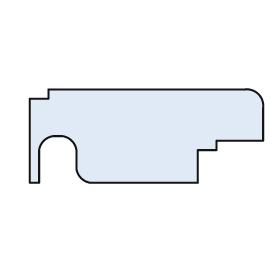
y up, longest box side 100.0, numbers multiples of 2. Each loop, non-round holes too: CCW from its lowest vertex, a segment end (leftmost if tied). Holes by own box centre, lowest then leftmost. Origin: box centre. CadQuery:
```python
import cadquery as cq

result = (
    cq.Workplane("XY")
    .moveTo(-50.0, -20.0)
    .lineTo(-46.0, -20.0)
    .lineTo(-46.0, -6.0)
    .threePointArc((-44.0, -2.0), (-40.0, 0.0))
    .lineTo(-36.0, 0.0)
    .threePointArc((-32.0, -2.0), (-30.0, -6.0))
    .lineTo(-30.0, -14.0)
    .threePointArc((-28.0, -18.0), (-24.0, -20.0))
    .lineTo(22.0, -20.0)
    .lineTo(22.0, -6.0)
    .lineTo(30.0, -6.0)
    .lineTo(30.0, -2.0)
    .lineTo(50.0, -2.0)
    .lineTo(50.0, 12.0)
    .threePointArc((48.0, 18.0), (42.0, 20.0))
    .lineTo(-42.0, 20.0)
    .lineTo(-42.0, 16.0)
    .lineTo(-50.0, 16.0)
    .close()
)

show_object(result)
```